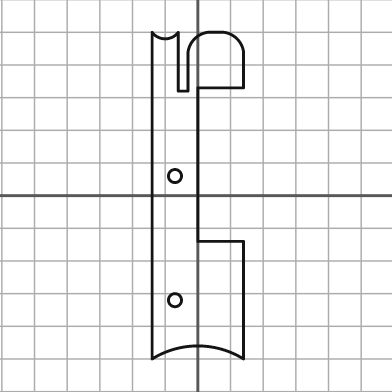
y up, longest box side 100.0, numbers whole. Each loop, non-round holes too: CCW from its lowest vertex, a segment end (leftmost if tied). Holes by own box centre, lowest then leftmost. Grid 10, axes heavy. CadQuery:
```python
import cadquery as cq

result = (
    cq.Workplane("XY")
    .moveTo(-14.0, -50.0)
    .threePointArc((0.0, -46.0), (14.0, -50.0))
    .lineTo(14.0, -14.0)
    .lineTo(0.0, -14.0)
    .lineTo(0.0, 33.0)
    .lineTo(14.0, 33.0)
    .lineTo(14.0, 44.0)
    .threePointArc((12.0, 48.0), (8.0, 50.0))
    .lineTo(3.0, 50.0)
    .threePointArc((-1.0, 48.0), (-3.0, 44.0))
    .lineTo(-3.0, 32.0)
    .lineTo(-6.0, 32.0)
    .lineTo(-6.0, 50.0)
    .threePointArc((-10.0, 48.0), (-14.0, 50.0))
    .close()
    .moveTo(-7.0, -32.0)
    .circle(2.0)
    .moveTo(-7.0, 6.0)
    .circle(2.0)
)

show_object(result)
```